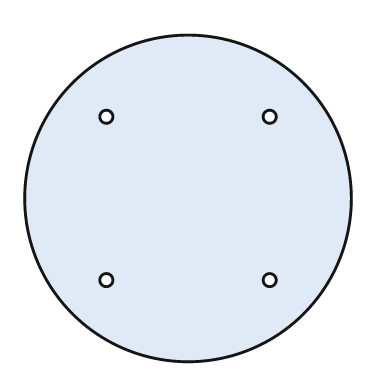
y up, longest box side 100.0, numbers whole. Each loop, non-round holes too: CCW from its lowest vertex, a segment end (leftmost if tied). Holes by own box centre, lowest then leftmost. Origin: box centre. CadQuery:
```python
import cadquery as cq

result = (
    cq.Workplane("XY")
    .moveTo(0.0, 0.0)
    .circle(50.0)
    .moveTo(-25.0, -25.0)
    .circle(2.0)
    .moveTo(25.0, -25.0)
    .circle(2.0)
    .moveTo(-25.0, 25.0)
    .circle(2.0)
    .moveTo(25.0, 25.0)
    .circle(2.0)
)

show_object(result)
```